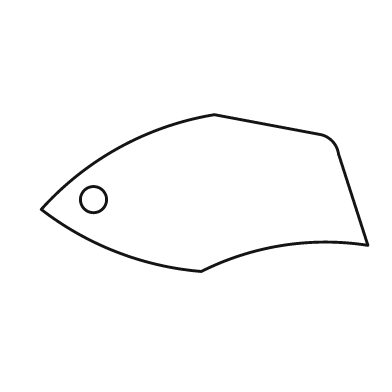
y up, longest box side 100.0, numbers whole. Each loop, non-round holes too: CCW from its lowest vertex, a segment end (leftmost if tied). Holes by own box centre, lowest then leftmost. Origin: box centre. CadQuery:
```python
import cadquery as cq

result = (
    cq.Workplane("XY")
    .moveTo(-1.0, -24.0)
    .threePointArc((24.0, -16.0), (50.0, -16.0))
    .lineTo(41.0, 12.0)
    .threePointArc((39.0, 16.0), (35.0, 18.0))
    .lineTo(3.0, 24.0)
    .threePointArc((-26.0, 14.0), (-50.0, -5.0))
    .threePointArc((-27.0, -18.0), (-1.0, -24.0))
    .close()
    .moveTo(-34.0, -2.0)
    .circle(4.0)
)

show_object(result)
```